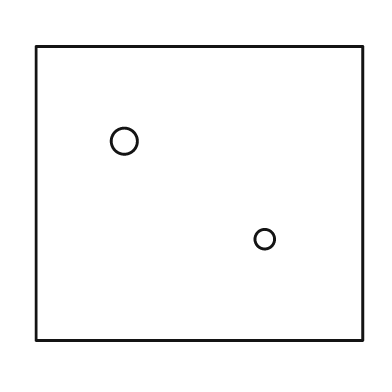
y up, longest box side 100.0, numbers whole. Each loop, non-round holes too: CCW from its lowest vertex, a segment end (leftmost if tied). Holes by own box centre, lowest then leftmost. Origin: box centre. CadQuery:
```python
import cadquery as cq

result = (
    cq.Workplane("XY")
    .moveTo(-50.0, -45.0)
    .lineTo(50.0, -45.0)
    .lineTo(50.0, 45.0)
    .lineTo(-50.0, 45.0)
    .close()
    .moveTo(20.0, -14.0)
    .circle(3.0)
    .moveTo(-23.0, 16.0)
    .circle(4.0)
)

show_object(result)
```